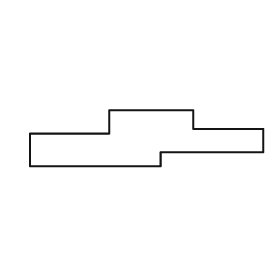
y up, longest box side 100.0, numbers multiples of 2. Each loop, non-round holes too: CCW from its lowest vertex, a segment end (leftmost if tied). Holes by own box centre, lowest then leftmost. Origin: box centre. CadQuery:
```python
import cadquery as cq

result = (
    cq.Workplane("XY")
    .moveTo(-50.0, -12.0)
    .lineTo(6.0, -12.0)
    .lineTo(6.0, -6.0)
    .lineTo(50.0, -6.0)
    .lineTo(50.0, 4.0)
    .lineTo(20.0, 4.0)
    .lineTo(20.0, 12.0)
    .lineTo(-16.0, 12.0)
    .lineTo(-16.0, 2.0)
    .lineTo(-50.0, 2.0)
    .close()
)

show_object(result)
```